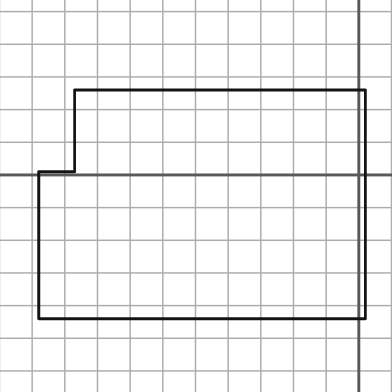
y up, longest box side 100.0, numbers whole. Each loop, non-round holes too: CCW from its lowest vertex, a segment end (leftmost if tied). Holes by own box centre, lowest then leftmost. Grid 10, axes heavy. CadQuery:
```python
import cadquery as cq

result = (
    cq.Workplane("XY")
    .moveTo(-98.0, -44.0)
    .lineTo(2.0, -44.0)
    .lineTo(2.0, 26.0)
    .lineTo(-87.0, 26.0)
    .lineTo(-87.0, 1.0)
    .lineTo(-98.0, 1.0)
    .close()
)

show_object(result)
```